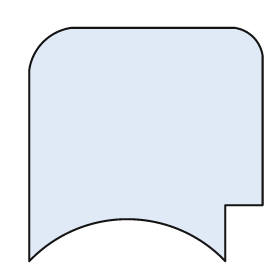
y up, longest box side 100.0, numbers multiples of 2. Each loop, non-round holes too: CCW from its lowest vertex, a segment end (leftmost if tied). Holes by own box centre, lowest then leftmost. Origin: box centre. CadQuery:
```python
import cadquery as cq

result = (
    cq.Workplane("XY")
    .moveTo(-50.0, -50.0)
    .threePointArc((-8.0, -32.0), (34.0, -50.0))
    .lineTo(34.0, -26.0)
    .lineTo(50.0, -26.0)
    .lineTo(50.0, 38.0)
    .threePointArc((46.0, 46.0), (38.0, 50.0))
    .lineTo(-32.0, 50.0)
    .threePointArc((-44.0, 44.0), (-50.0, 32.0))
    .close()
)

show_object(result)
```